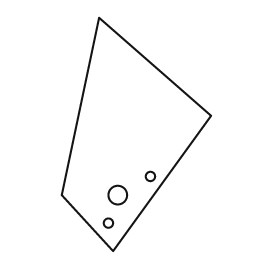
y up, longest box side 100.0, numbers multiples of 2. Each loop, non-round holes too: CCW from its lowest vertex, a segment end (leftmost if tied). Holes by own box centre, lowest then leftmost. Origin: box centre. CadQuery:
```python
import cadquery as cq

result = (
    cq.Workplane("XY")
    .moveTo(-10.0, -50.0)
    .lineTo(32.0, 8.0)
    .lineTo(-16.0, 50.0)
    .lineTo(-32.0, -26.0)
    .close()
    .moveTo(-12.0, -38.0)
    .circle(2.0)
    .moveTo(-8.0, -26.0)
    .circle(4.0)
    .moveTo(6.0, -18.0)
    .circle(2.0)
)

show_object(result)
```